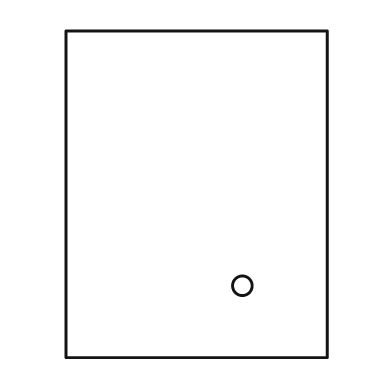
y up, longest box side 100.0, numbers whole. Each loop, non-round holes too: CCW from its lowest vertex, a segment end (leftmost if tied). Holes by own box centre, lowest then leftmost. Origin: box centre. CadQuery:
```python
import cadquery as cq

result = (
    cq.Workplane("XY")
    .moveTo(-40.0, -50.0)
    .lineTo(40.0, -50.0)
    .lineTo(40.0, 50.0)
    .lineTo(-40.0, 50.0)
    .close()
    .moveTo(14.0, -28.0)
    .circle(3.0)
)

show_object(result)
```